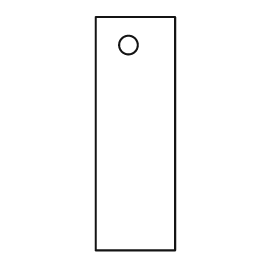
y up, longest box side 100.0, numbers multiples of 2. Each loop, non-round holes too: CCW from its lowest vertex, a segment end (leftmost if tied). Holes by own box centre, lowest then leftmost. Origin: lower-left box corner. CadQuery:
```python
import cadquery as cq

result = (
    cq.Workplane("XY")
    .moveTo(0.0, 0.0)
    .lineTo(34.0, 0.0)
    .lineTo(34.0, 100.0)
    .lineTo(0.0, 100.0)
    .close()
    .moveTo(14.0, 88.0)
    .circle(4.0)
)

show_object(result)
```